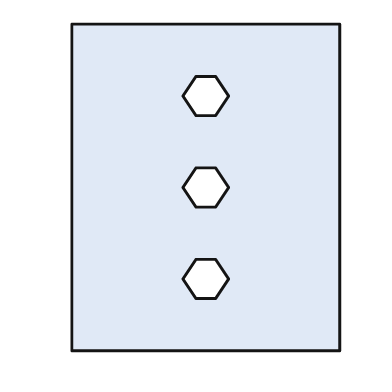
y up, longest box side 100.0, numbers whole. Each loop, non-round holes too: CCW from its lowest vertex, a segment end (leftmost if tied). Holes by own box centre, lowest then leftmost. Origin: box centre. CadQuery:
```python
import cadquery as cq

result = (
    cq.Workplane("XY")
    .moveTo(-41.0, -50.0)
    .lineTo(41.0, -50.0)
    .lineTo(41.0, 50.0)
    .lineTo(-41.0, 50.0)
    .close()
    .moveTo(-3.0, -34.0)
    .lineTo(3.0, -34.0)
    .lineTo(7.0, -28.0)
    .lineTo(3.0, -22.0)
    .lineTo(-3.0, -22.0)
    .lineTo(-7.0, -28.0)
    .close()
    .moveTo(-3.0, -6.0)
    .lineTo(3.0, -6.0)
    .lineTo(7.0, 0.0)
    .lineTo(3.0, 6.0)
    .lineTo(-3.0, 6.0)
    .lineTo(-7.0, 0.0)
    .close()
    .moveTo(-3.0, 22.0)
    .lineTo(3.0, 22.0)
    .lineTo(7.0, 28.0)
    .lineTo(3.0, 34.0)
    .lineTo(-3.0, 34.0)
    .lineTo(-7.0, 28.0)
    .close()
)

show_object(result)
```